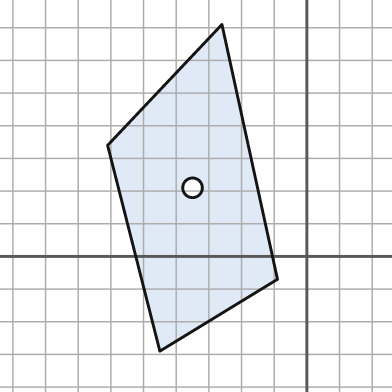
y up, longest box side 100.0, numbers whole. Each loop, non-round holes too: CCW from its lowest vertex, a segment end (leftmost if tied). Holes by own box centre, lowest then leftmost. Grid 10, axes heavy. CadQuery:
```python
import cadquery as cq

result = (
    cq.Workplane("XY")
    .moveTo(-45.0, -29.0)
    .lineTo(-9.0, -7.0)
    .lineTo(-26.0, 71.0)
    .lineTo(-61.0, 34.0)
    .close()
    .moveTo(-35.0, 21.0)
    .circle(3.0)
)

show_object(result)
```